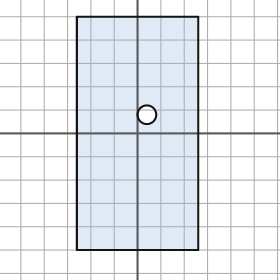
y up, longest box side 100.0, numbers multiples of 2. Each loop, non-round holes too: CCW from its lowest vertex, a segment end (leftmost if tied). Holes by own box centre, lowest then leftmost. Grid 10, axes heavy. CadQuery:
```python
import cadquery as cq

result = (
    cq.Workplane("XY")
    .moveTo(-26.0, -50.0)
    .lineTo(26.0, -50.0)
    .lineTo(26.0, 50.0)
    .lineTo(-26.0, 50.0)
    .close()
    .moveTo(4.0, 8.0)
    .circle(4.0)
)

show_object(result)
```